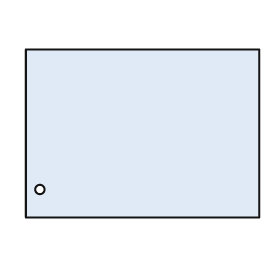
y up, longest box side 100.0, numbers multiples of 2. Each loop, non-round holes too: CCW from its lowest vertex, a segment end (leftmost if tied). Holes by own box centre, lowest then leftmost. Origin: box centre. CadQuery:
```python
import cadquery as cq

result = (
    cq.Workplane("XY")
    .moveTo(-50.0, -36.0)
    .lineTo(50.0, -36.0)
    .lineTo(50.0, 36.0)
    .lineTo(-50.0, 36.0)
    .close()
    .moveTo(-44.0, -24.0)
    .circle(2.0)
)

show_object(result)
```